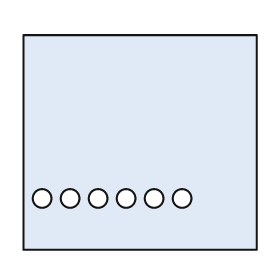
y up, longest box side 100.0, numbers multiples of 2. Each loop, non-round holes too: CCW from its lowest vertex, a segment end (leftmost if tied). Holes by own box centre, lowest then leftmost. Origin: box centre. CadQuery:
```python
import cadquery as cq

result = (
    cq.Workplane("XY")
    .moveTo(-50.0, -46.0)
    .lineTo(50.0, -46.0)
    .lineTo(50.0, 46.0)
    .lineTo(-50.0, 46.0)
    .close()
    .moveTo(-42.0, -24.0)
    .circle(4.0)
    .moveTo(-30.0, -24.0)
    .circle(4.0)
    .moveTo(-18.0, -24.0)
    .circle(4.0)
    .moveTo(-6.0, -24.0)
    .circle(4.0)
    .moveTo(6.0, -24.0)
    .circle(4.0)
    .moveTo(18.0, -24.0)
    .circle(4.0)
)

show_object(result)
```